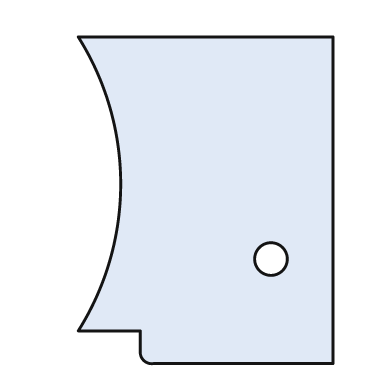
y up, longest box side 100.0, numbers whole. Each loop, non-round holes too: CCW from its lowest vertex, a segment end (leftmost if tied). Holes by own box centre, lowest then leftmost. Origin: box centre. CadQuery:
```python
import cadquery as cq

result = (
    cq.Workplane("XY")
    .moveTo(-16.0, -50.0)
    .lineTo(39.0, -50.0)
    .lineTo(39.0, 50.0)
    .lineTo(-39.0, 50.0)
    .threePointArc((-26.0, 5.0), (-39.0, -40.0))
    .lineTo(-20.0, -40.0)
    .lineTo(-20.0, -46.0)
    .threePointArc((-19.0, -49.0), (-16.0, -50.0))
    .close()
    .moveTo(20.0, -18.0)
    .circle(5.0)
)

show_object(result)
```